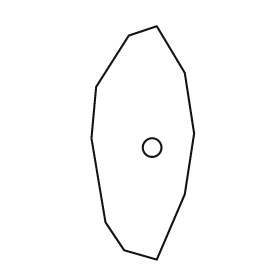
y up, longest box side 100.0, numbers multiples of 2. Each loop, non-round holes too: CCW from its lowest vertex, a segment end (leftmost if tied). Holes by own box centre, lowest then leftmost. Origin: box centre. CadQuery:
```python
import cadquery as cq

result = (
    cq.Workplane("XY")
    .moveTo(6.0, -50.0)
    .lineTo(18.0, -22.0)
    .lineTo(22.0, 4.0)
    .lineTo(18.0, 30.0)
    .lineTo(6.0, 50.0)
    .lineTo(-6.0, 46.0)
    .lineTo(-20.0, 24.0)
    .lineTo(-22.0, 2.0)
    .lineTo(-16.0, -34.0)
    .lineTo(-8.0, -46.0)
    .close()
    .moveTo(4.0, -2.0)
    .circle(4.0)
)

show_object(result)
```